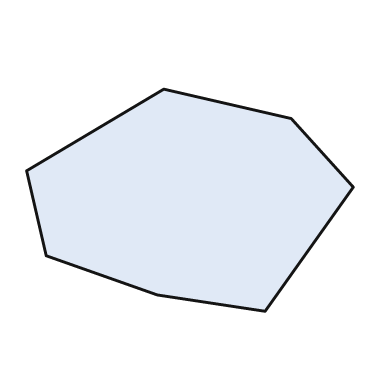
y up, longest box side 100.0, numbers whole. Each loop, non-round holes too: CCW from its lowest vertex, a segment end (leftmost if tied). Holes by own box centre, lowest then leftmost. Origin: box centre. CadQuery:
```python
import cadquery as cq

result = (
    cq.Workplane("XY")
    .moveTo(23.0, -34.0)
    .lineTo(50.0, 4.0)
    .lineTo(31.0, 25.0)
    .lineTo(-8.0, 34.0)
    .lineTo(-50.0, 9.0)
    .lineTo(-44.0, -17.0)
    .lineTo(-10.0, -29.0)
    .close()
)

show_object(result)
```